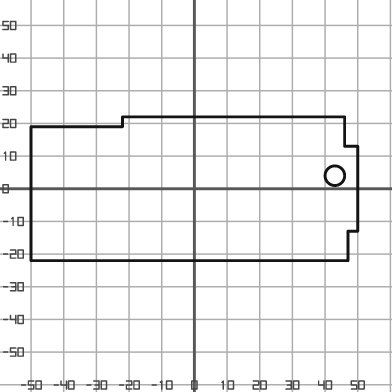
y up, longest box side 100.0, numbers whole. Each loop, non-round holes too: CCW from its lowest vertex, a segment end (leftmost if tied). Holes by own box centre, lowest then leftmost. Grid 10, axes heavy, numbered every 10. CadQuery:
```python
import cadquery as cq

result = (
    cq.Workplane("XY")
    .moveTo(-50.0, -22.0)
    .lineTo(47.0, -22.0)
    .lineTo(47.0, -13.0)
    .lineTo(50.0, -13.0)
    .lineTo(50.0, 13.0)
    .lineTo(46.0, 13.0)
    .lineTo(46.0, 22.0)
    .lineTo(-22.0, 22.0)
    .lineTo(-22.0, 19.0)
    .lineTo(-50.0, 19.0)
    .close()
    .moveTo(43.0, 4.0)
    .circle(3.0)
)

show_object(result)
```